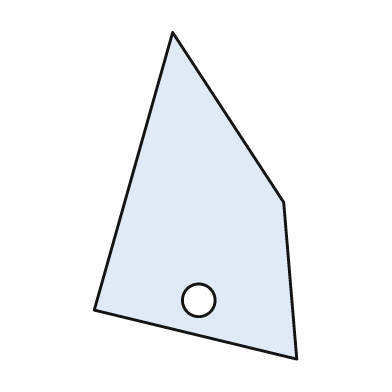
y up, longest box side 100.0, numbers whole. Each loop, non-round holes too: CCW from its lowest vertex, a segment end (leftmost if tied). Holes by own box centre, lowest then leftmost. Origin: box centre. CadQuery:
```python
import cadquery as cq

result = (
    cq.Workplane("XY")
    .moveTo(31.0, -50.0)
    .lineTo(27.0, -2.0)
    .lineTo(-7.0, 50.0)
    .lineTo(-31.0, -35.0)
    .close()
    .moveTo(1.0, -32.0)
    .circle(5.0)
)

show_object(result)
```